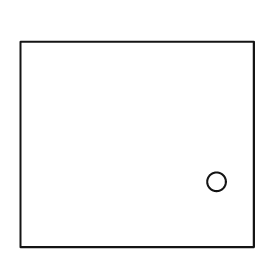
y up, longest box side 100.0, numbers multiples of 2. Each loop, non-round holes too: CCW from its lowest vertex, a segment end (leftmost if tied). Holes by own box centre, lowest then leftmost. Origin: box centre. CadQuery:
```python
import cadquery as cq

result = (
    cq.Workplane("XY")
    .moveTo(-50.0, -44.0)
    .lineTo(50.0, -44.0)
    .lineTo(50.0, 44.0)
    .lineTo(-50.0, 44.0)
    .close()
    .moveTo(34.0, -16.0)
    .circle(4.0)
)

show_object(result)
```